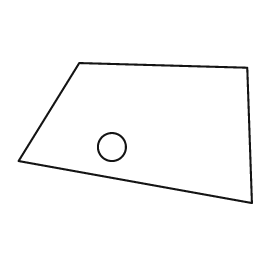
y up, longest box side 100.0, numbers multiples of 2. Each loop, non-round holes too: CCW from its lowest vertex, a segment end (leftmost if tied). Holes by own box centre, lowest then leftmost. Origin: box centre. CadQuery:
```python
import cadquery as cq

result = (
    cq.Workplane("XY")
    .moveTo(50.0, -30.0)
    .lineTo(48.0, 28.0)
    .lineTo(-24.0, 30.0)
    .lineTo(-50.0, -12.0)
    .close()
    .moveTo(-10.0, -6.0)
    .circle(6.0)
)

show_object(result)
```